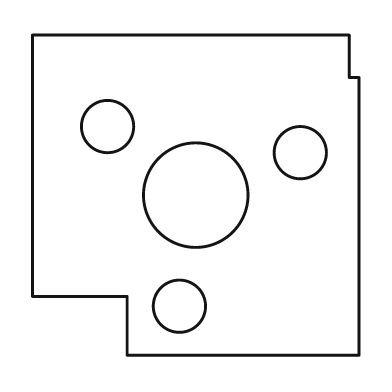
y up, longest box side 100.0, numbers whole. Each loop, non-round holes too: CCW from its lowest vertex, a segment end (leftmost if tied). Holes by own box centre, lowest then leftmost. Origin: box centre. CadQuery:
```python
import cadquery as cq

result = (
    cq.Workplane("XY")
    .moveTo(-21.0, -49.0)
    .lineTo(50.0, -49.0)
    .lineTo(50.0, 36.0)
    .lineTo(47.0, 36.0)
    .lineTo(47.0, 49.0)
    .lineTo(-50.0, 49.0)
    .lineTo(-50.0, -31.0)
    .lineTo(-21.0, -31.0)
    .close()
    .moveTo(-5.0, -34.0)
    .circle(8.0)
    .moveTo(0.0, 0.0)
    .circle(16.0)
    .moveTo(32.0, 13.0)
    .circle(8.0)
    .moveTo(-27.0, 21.0)
    .circle(8.0)
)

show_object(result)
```